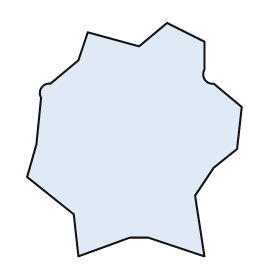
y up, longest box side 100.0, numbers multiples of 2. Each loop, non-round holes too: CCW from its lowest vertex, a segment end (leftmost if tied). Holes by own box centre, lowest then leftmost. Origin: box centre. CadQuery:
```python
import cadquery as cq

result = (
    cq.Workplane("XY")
    .moveTo(-24.0, -50.0)
    .lineTo(-2.0, -42.0)
    .lineTo(6.0, -42.0)
    .lineTo(30.0, -50.0)
    .lineTo(26.0, -24.0)
    .lineTo(34.0, -12.0)
    .lineTo(44.0, -4.0)
    .lineTo(46.0, 14.0)
    .lineTo(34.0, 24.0)
    .threePointArc((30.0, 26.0), (30.0, 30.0))
    .lineTo(30.0, 42.0)
    .lineTo(14.0, 50.0)
    .lineTo(2.0, 40.0)
    .lineTo(-20.0, 46.0)
    .lineTo(-24.0, 34.0)
    .lineTo(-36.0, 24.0)
    .threePointArc((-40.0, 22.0), (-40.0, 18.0))
    .lineTo(-42.0, -2.0)
    .lineTo(-46.0, -16.0)
    .lineTo(-26.0, -32.0)
    .close()
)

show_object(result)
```